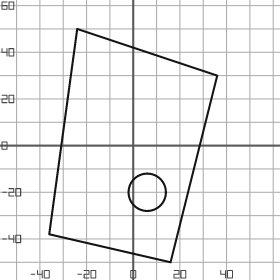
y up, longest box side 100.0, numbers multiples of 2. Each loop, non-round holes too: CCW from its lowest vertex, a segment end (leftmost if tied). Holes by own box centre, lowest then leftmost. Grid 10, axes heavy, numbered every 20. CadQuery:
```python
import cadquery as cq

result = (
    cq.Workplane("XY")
    .moveTo(16.0, -50.0)
    .lineTo(36.0, 30.0)
    .lineTo(-24.0, 50.0)
    .lineTo(-36.0, -38.0)
    .close()
    .moveTo(6.0, -20.0)
    .circle(8.0)
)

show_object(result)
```